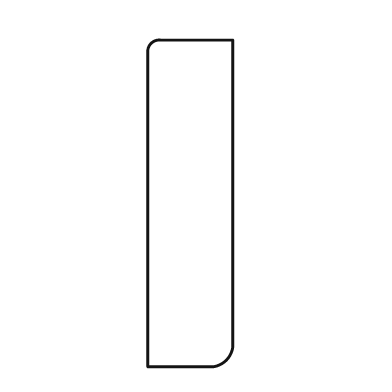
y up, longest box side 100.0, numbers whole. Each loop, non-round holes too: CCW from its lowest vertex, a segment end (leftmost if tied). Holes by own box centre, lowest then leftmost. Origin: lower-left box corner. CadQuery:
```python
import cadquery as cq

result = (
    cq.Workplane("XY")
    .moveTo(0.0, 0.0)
    .lineTo(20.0, 0.0)
    .threePointArc((24.0, 2.0), (26.0, 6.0))
    .lineTo(26.0, 100.0)
    .lineTo(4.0, 100.0)
    .threePointArc((1.0, 99.0), (0.0, 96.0))
    .close()
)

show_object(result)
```